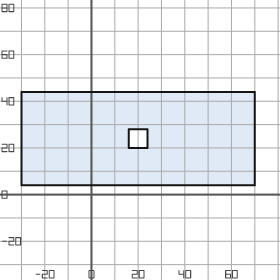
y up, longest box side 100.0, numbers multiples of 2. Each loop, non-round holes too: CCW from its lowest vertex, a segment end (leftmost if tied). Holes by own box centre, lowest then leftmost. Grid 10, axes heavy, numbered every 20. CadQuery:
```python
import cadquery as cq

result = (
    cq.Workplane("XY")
    .moveTo(-30.0, 4.0)
    .lineTo(70.0, 4.0)
    .lineTo(70.0, 44.0)
    .lineTo(-30.0, 44.0)
    .close()
    .moveTo(16.0, 20.0)
    .lineTo(24.0, 20.0)
    .lineTo(24.0, 28.0)
    .lineTo(16.0, 28.0)
    .close()
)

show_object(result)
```